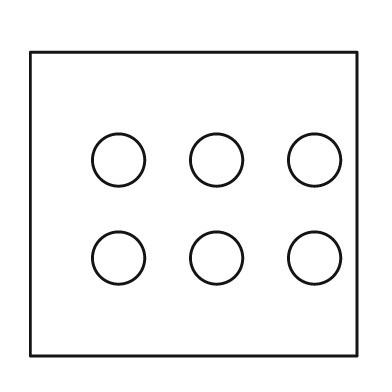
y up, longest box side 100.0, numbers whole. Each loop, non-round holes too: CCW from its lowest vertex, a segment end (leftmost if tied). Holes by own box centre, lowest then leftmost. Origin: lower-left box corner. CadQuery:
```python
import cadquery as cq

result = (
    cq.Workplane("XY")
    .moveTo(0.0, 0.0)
    .lineTo(100.0, 0.0)
    .lineTo(100.0, 93.0)
    .lineTo(0.0, 93.0)
    .close()
    .moveTo(27.0, 30.0)
    .circle(8.0)
    .moveTo(57.0, 30.0)
    .circle(8.0)
    .moveTo(87.0, 30.0)
    .circle(8.0)
    .moveTo(27.0, 60.0)
    .circle(8.0)
    .moveTo(57.0, 60.0)
    .circle(8.0)
    .moveTo(87.0, 60.0)
    .circle(8.0)
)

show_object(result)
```